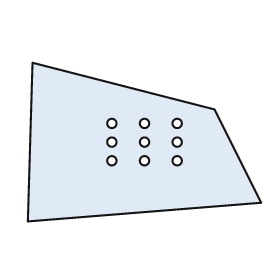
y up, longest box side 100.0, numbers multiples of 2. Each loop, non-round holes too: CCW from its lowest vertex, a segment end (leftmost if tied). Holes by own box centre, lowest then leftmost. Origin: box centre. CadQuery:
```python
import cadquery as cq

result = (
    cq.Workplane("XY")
    .moveTo(-50.0, -34.0)
    .lineTo(50.0, -26.0)
    .lineTo(30.0, 14.0)
    .lineTo(-48.0, 34.0)
    .close()
    .moveTo(-14.0, -8.0)
    .circle(2.0)
    .moveTo(0.0, -8.0)
    .circle(2.0)
    .moveTo(14.0, -8.0)
    .circle(2.0)
    .moveTo(-14.0, 0.0)
    .circle(2.0)
    .moveTo(0.0, 0.0)
    .circle(2.0)
    .moveTo(14.0, 0.0)
    .circle(2.0)
    .moveTo(-14.0, 8.0)
    .circle(2.0)
    .moveTo(0.0, 8.0)
    .circle(2.0)
    .moveTo(14.0, 8.0)
    .circle(2.0)
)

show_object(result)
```